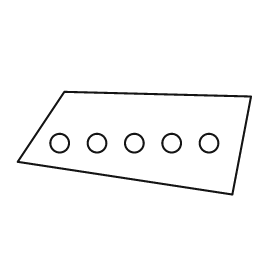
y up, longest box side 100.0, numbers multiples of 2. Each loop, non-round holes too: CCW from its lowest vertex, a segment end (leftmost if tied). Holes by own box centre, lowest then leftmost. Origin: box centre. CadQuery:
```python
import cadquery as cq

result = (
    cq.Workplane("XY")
    .moveTo(42.0, -22.0)
    .lineTo(50.0, 20.0)
    .lineTo(-30.0, 22.0)
    .lineTo(-50.0, -8.0)
    .close()
    .moveTo(-32.0, 0.0)
    .circle(4.0)
    .moveTo(-16.0, 0.0)
    .circle(4.0)
    .moveTo(0.0, 0.0)
    .circle(4.0)
    .moveTo(16.0, 0.0)
    .circle(4.0)
    .moveTo(32.0, 0.0)
    .circle(4.0)
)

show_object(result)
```